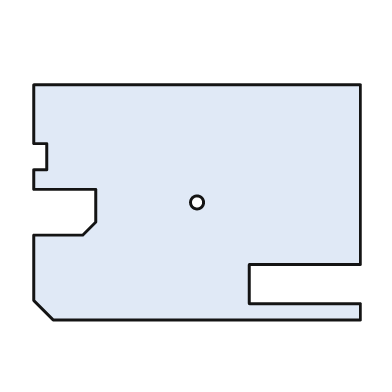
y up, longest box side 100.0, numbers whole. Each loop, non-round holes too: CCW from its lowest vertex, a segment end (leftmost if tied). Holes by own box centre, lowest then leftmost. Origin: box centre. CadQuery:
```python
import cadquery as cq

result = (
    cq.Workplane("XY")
    .moveTo(-44.0, -36.0)
    .lineTo(50.0, -36.0)
    .lineTo(50.0, -31.0)
    .lineTo(16.0, -31.0)
    .lineTo(16.0, -19.0)
    .lineTo(50.0, -19.0)
    .lineTo(50.0, 36.0)
    .lineTo(-50.0, 36.0)
    .lineTo(-50.0, 18.0)
    .lineTo(-46.0, 18.0)
    .lineTo(-46.0, 10.0)
    .lineTo(-50.0, 10.0)
    .lineTo(-50.0, 4.0)
    .lineTo(-31.0, 4.0)
    .lineTo(-31.0, -6.0)
    .lineTo(-35.0, -10.0)
    .lineTo(-50.0, -10.0)
    .lineTo(-50.0, -30.0)
    .close()
    .moveTo(0.0, 0.0)
    .circle(2.0)
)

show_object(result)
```